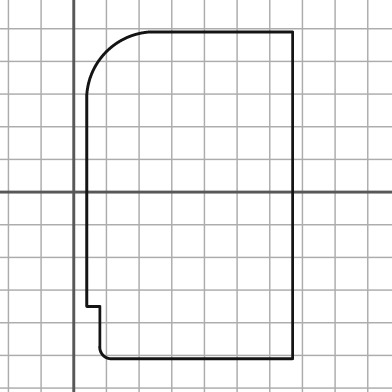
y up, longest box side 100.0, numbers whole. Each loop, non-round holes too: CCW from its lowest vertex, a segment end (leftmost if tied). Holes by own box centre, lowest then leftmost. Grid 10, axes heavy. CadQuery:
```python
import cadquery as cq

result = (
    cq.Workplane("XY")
    .moveTo(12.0, -51.0)
    .lineTo(67.0, -51.0)
    .lineTo(67.0, 49.0)
    .lineTo(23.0, 49.0)
    .threePointArc((10.0, 43.0), (4.0, 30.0))
    .lineTo(4.0, -35.0)
    .lineTo(8.0, -35.0)
    .lineTo(8.0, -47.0)
    .threePointArc((9.0, -50.0), (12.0, -51.0))
    .close()
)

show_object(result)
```